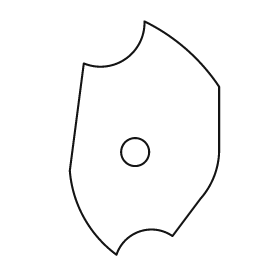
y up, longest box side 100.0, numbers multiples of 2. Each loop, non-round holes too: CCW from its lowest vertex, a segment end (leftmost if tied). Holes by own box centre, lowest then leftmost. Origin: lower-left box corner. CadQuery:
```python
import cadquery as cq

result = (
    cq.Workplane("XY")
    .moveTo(20.0, 0.0)
    .threePointArc((30.0, 10.0), (44.0, 8.0))
    .lineTo(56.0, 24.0)
    .threePointArc((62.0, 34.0), (64.0, 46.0))
    .lineTo(64.0, 72.0)
    .threePointArc((50.0, 88.0), (32.0, 100.0))
    .threePointArc((24.0, 84.0), (6.0, 82.0))
    .lineTo(0.0, 36.0)
    .threePointArc((6.0, 16.0), (20.0, 0.0))
    .close()
    .moveTo(28.0, 44.0)
    .circle(6.0)
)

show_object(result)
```